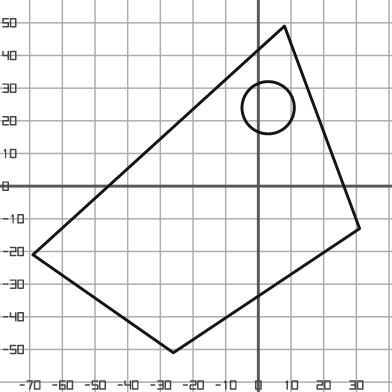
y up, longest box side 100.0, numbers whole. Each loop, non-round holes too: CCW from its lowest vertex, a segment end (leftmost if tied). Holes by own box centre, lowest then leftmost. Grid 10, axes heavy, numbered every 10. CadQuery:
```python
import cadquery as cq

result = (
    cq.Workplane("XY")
    .moveTo(-26.0, -51.0)
    .lineTo(31.0, -13.0)
    .lineTo(8.0, 49.0)
    .lineTo(-69.0, -21.0)
    .close()
    .moveTo(3.0, 24.0)
    .circle(8.0)
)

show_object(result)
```